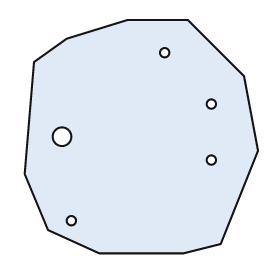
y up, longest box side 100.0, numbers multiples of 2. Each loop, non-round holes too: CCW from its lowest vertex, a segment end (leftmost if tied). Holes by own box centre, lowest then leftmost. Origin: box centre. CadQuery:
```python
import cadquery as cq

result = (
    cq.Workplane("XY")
    .moveTo(-18.0, -50.0)
    .lineTo(18.0, -50.0)
    .lineTo(34.0, -46.0)
    .lineTo(50.0, -6.0)
    .lineTo(44.0, 26.0)
    .lineTo(20.0, 50.0)
    .lineTo(-6.0, 50.0)
    .lineTo(-32.0, 42.0)
    .lineTo(-46.0, 32.0)
    .lineTo(-50.0, -16.0)
    .lineTo(-40.0, -40.0)
    .close()
    .moveTo(-30.0, -36.0)
    .circle(2.0)
    .moveTo(30.0, -10.0)
    .circle(2.0)
    .moveTo(-34.0, 0.0)
    .circle(4.0)
    .moveTo(30.0, 14.0)
    .circle(2.0)
    .moveTo(10.0, 36.0)
    .circle(2.0)
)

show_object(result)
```